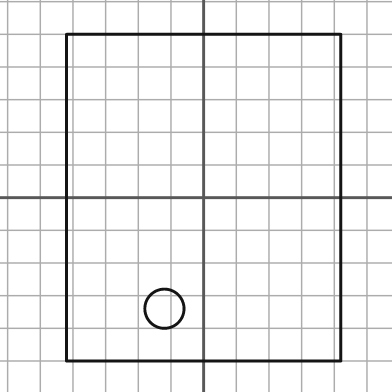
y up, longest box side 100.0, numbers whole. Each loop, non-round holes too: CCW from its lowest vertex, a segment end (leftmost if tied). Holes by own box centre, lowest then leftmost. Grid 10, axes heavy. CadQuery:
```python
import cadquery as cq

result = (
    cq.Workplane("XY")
    .moveTo(-42.0, -50.0)
    .lineTo(42.0, -50.0)
    .lineTo(42.0, 50.0)
    .lineTo(-42.0, 50.0)
    .close()
    .moveTo(-12.0, -34.0)
    .circle(6.0)
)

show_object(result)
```